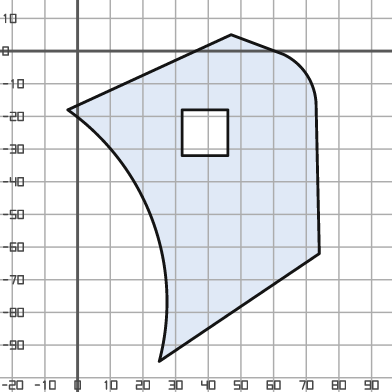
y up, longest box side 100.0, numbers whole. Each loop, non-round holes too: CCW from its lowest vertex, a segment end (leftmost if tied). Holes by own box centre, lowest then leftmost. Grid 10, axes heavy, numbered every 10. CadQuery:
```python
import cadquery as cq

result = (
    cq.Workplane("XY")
    .moveTo(25.0, -95.0)
    .lineTo(74.0, -62.0)
    .lineTo(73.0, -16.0)
    .threePointArc((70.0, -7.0), (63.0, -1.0))
    .lineTo(47.0, 5.0)
    .lineTo(-3.0, -18.0)
    .threePointArc((23.0, -52.0), (25.0, -95.0))
    .close()
    .moveTo(32.0, -32.0)
    .lineTo(46.0, -32.0)
    .lineTo(46.0, -18.0)
    .lineTo(32.0, -18.0)
    .close()
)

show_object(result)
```